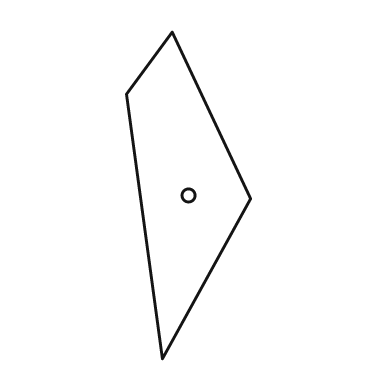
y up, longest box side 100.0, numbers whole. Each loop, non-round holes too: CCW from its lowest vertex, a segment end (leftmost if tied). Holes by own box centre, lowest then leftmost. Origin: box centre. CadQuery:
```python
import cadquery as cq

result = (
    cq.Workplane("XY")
    .moveTo(-8.0, -50.0)
    .lineTo(19.0, -1.0)
    .lineTo(-5.0, 50.0)
    .lineTo(-19.0, 31.0)
    .close()
    .moveTo(0.0, 0.0)
    .circle(2.0)
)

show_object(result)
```